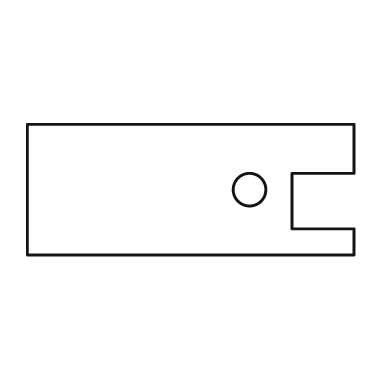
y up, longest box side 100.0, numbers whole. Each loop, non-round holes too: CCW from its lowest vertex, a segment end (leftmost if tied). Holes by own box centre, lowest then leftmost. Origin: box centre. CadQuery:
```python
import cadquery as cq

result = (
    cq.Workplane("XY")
    .moveTo(-50.0, -20.0)
    .lineTo(50.0, -20.0)
    .lineTo(50.0, -12.0)
    .lineTo(31.0, -12.0)
    .lineTo(31.0, 5.0)
    .lineTo(50.0, 5.0)
    .lineTo(50.0, 20.0)
    .lineTo(-50.0, 20.0)
    .close()
    .moveTo(18.0, 0.0)
    .circle(5.0)
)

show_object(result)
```